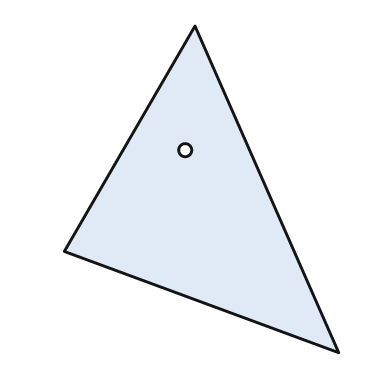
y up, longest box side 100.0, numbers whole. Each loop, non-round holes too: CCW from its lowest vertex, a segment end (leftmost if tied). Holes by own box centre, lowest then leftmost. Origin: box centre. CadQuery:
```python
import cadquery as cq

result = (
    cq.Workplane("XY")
    .moveTo(42.0, -50.0)
    .lineTo(-2.0, 50.0)
    .lineTo(-42.0, -19.0)
    .close()
    .moveTo(-5.0, 12.0)
    .circle(2.0)
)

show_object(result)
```